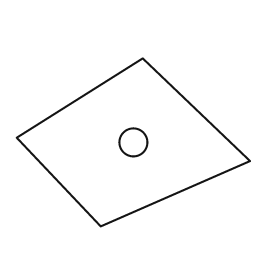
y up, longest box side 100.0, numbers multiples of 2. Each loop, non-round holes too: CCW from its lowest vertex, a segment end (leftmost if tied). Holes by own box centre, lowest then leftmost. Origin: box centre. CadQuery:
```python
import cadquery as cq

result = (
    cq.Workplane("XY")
    .moveTo(-14.0, -36.0)
    .lineTo(50.0, -8.0)
    .lineTo(4.0, 36.0)
    .lineTo(-50.0, 2.0)
    .close()
    .moveTo(0.0, 0.0)
    .circle(6.0)
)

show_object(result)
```